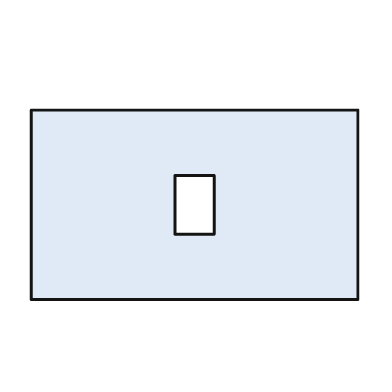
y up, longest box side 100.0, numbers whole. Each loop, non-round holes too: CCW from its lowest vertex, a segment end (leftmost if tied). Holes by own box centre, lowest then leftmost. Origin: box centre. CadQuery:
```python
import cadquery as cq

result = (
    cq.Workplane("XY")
    .moveTo(-50.0, -29.0)
    .lineTo(50.0, -29.0)
    .lineTo(50.0, 29.0)
    .lineTo(-50.0, 29.0)
    .close()
    .moveTo(-6.0, -9.0)
    .lineTo(6.0, -9.0)
    .lineTo(6.0, 9.0)
    .lineTo(-6.0, 9.0)
    .close()
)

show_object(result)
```